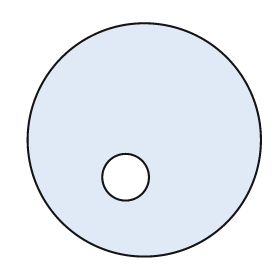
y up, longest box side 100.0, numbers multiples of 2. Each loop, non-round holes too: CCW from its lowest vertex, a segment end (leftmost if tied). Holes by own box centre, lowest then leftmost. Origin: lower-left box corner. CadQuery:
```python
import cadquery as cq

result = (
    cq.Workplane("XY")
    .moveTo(50.0, 50.0)
    .circle(50.0)
    .moveTo(42.0, 34.0)
    .circle(10.0)
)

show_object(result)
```